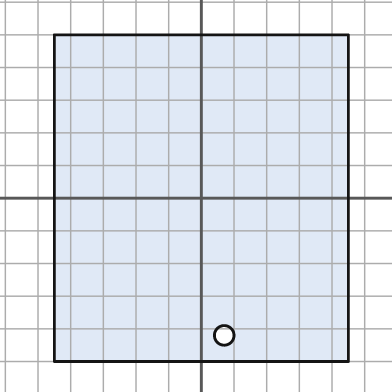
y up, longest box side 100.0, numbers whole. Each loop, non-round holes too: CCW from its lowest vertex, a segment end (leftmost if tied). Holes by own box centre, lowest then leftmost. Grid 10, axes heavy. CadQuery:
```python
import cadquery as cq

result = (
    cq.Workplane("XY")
    .moveTo(-45.0, -50.0)
    .lineTo(45.0, -50.0)
    .lineTo(45.0, 50.0)
    .lineTo(-45.0, 50.0)
    .close()
    .moveTo(7.0, -42.0)
    .circle(3.0)
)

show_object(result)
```